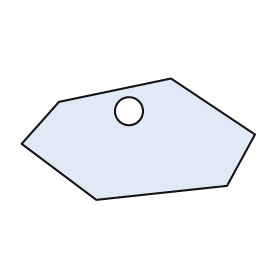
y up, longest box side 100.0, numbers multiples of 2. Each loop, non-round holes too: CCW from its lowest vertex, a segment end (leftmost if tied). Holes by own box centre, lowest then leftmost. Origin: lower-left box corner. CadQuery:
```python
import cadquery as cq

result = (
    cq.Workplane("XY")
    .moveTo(32.0, 0.0)
    .lineTo(88.0, 6.0)
    .lineTo(100.0, 28.0)
    .lineTo(64.0, 52.0)
    .lineTo(16.0, 42.0)
    .lineTo(0.0, 24.0)
    .close()
    .moveTo(46.0, 38.0)
    .circle(6.0)
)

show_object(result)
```